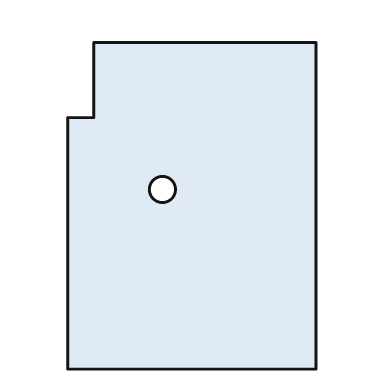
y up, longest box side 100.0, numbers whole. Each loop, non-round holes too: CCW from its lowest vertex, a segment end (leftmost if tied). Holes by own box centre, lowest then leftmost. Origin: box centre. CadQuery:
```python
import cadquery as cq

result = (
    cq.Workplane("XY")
    .moveTo(-38.0, -50.0)
    .lineTo(38.0, -50.0)
    .lineTo(38.0, 50.0)
    .lineTo(-30.0, 50.0)
    .lineTo(-30.0, 27.0)
    .lineTo(-38.0, 27.0)
    .close()
    .moveTo(-9.0, 5.0)
    .circle(4.0)
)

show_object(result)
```